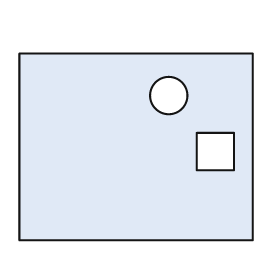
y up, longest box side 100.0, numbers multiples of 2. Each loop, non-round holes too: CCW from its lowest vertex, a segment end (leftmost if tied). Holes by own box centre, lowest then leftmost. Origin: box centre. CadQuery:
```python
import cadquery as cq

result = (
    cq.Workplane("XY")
    .moveTo(-50.0, -40.0)
    .lineTo(50.0, -40.0)
    .lineTo(50.0, 40.0)
    .lineTo(-50.0, 40.0)
    .close()
    .moveTo(26.0, -10.0)
    .lineTo(42.0, -10.0)
    .lineTo(42.0, 6.0)
    .lineTo(26.0, 6.0)
    .close()
    .moveTo(14.0, 22.0)
    .circle(8.0)
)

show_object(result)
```